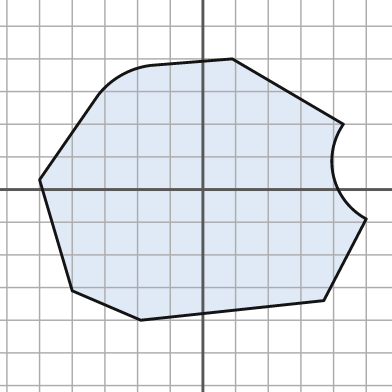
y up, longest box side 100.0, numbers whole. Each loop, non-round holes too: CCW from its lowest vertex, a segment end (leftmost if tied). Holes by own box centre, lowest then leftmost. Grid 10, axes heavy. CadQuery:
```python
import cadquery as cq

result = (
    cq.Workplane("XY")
    .moveTo(-19.0, -40.0)
    .lineTo(37.0, -34.0)
    .lineTo(50.0, -9.0)
    .threePointArc((40.0, 4.0), (43.0, 20.0))
    .lineTo(9.0, 40.0)
    .lineTo(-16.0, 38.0)
    .threePointArc((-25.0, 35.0), (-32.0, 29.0))
    .lineTo(-50.0, 3.0)
    .lineTo(-40.0, -31.0)
    .close()
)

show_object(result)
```